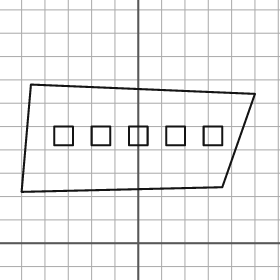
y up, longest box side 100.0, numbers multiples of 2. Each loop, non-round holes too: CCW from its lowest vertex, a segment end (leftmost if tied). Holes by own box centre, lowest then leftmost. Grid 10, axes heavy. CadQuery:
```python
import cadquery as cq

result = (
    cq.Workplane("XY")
    .moveTo(-50.0, 22.0)
    .lineTo(36.0, 24.0)
    .lineTo(50.0, 64.0)
    .lineTo(-46.0, 68.0)
    .close()
    .moveTo(-36.0, 42.0)
    .lineTo(-28.0, 42.0)
    .lineTo(-28.0, 50.0)
    .lineTo(-36.0, 50.0)
    .close()
    .moveTo(-20.0, 42.0)
    .lineTo(-12.0, 42.0)
    .lineTo(-12.0, 50.0)
    .lineTo(-20.0, 50.0)
    .close()
    .moveTo(-4.0, 42.0)
    .lineTo(4.0, 42.0)
    .lineTo(4.0, 50.0)
    .lineTo(-4.0, 50.0)
    .close()
    .moveTo(12.0, 42.0)
    .lineTo(20.0, 42.0)
    .lineTo(20.0, 50.0)
    .lineTo(12.0, 50.0)
    .close()
    .moveTo(28.0, 42.0)
    .lineTo(36.0, 42.0)
    .lineTo(36.0, 50.0)
    .lineTo(28.0, 50.0)
    .close()
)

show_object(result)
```